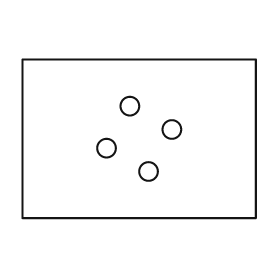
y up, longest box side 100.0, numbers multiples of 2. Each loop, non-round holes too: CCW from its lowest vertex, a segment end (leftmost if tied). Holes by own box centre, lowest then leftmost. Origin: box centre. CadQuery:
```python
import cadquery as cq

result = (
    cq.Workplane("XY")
    .moveTo(-50.0, -34.0)
    .lineTo(50.0, -34.0)
    .lineTo(50.0, 34.0)
    .lineTo(-50.0, 34.0)
    .close()
    .moveTo(4.0, -14.0)
    .circle(4.0)
    .moveTo(-14.0, -4.0)
    .circle(4.0)
    .moveTo(14.0, 4.0)
    .circle(4.0)
    .moveTo(-4.0, 14.0)
    .circle(4.0)
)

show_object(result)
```